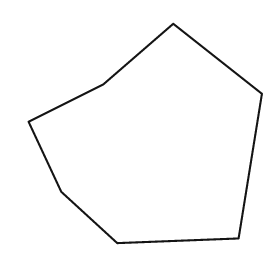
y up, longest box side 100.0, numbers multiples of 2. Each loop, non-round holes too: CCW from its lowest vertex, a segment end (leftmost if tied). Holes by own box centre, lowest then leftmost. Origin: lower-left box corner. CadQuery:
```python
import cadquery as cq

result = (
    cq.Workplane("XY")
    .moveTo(38.0, 0.0)
    .lineTo(90.0, 2.0)
    .lineTo(100.0, 64.0)
    .lineTo(62.0, 94.0)
    .lineTo(32.0, 68.0)
    .lineTo(0.0, 52.0)
    .lineTo(14.0, 22.0)
    .close()
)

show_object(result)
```